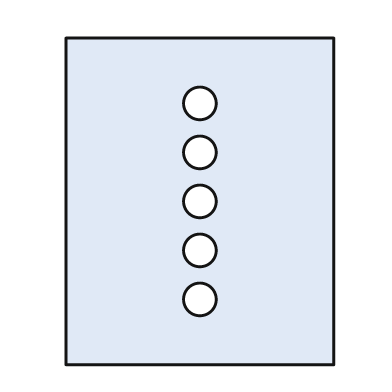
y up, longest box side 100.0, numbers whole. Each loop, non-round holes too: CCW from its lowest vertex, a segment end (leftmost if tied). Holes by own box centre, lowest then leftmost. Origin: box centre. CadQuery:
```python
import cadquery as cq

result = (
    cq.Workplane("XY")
    .moveTo(-41.0, -50.0)
    .lineTo(41.0, -50.0)
    .lineTo(41.0, 50.0)
    .lineTo(-41.0, 50.0)
    .close()
    .moveTo(0.0, -30.0)
    .circle(5.0)
    .moveTo(0.0, -15.0)
    .circle(5.0)
    .moveTo(0.0, 0.0)
    .circle(5.0)
    .moveTo(0.0, 15.0)
    .circle(5.0)
    .moveTo(0.0, 30.0)
    .circle(5.0)
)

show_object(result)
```